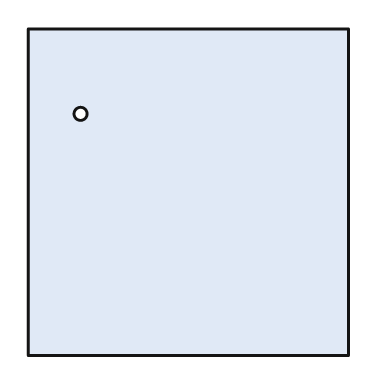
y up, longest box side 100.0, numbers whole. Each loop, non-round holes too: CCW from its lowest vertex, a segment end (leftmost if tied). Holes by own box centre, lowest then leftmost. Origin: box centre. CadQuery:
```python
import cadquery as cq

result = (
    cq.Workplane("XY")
    .moveTo(-49.0, -50.0)
    .lineTo(49.0, -50.0)
    .lineTo(49.0, 50.0)
    .lineTo(-49.0, 50.0)
    .close()
    .moveTo(-33.0, 24.0)
    .circle(2.0)
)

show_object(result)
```